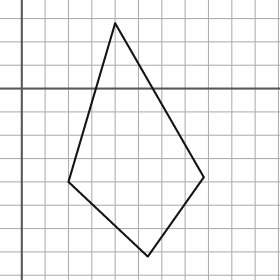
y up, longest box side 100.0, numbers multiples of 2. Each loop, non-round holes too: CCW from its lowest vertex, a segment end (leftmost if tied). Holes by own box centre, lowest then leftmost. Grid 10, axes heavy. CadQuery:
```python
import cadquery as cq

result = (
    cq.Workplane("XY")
    .moveTo(54.0, -72.0)
    .lineTo(78.0, -38.0)
    .lineTo(40.0, 28.0)
    .lineTo(20.0, -40.0)
    .close()
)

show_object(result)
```